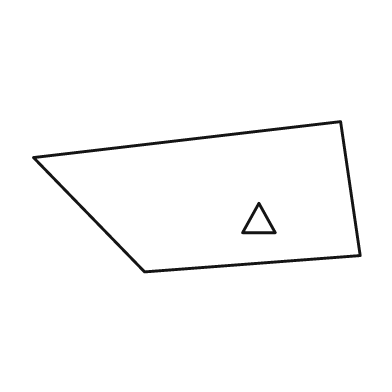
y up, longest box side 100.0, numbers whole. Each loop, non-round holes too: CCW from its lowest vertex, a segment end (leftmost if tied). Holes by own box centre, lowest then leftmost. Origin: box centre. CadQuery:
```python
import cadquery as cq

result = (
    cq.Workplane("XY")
    .moveTo(-16.0, -23.0)
    .lineTo(50.0, -18.0)
    .lineTo(44.0, 23.0)
    .lineTo(-50.0, 12.0)
    .close()
    .moveTo(14.0, -11.0)
    .lineTo(24.0, -11.0)
    .lineTo(19.0, -2.0)
    .close()
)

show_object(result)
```